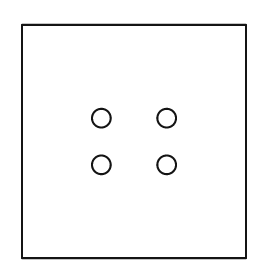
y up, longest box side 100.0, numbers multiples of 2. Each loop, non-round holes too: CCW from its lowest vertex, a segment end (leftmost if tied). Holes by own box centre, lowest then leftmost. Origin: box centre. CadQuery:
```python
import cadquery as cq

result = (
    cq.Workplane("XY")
    .moveTo(-48.0, -50.0)
    .lineTo(48.0, -50.0)
    .lineTo(48.0, 50.0)
    .lineTo(-48.0, 50.0)
    .close()
    .moveTo(-14.0, -10.0)
    .circle(4.0)
    .moveTo(14.0, -10.0)
    .circle(4.0)
    .moveTo(-14.0, 10.0)
    .circle(4.0)
    .moveTo(14.0, 10.0)
    .circle(4.0)
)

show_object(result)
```